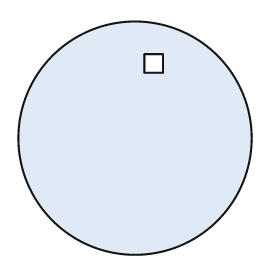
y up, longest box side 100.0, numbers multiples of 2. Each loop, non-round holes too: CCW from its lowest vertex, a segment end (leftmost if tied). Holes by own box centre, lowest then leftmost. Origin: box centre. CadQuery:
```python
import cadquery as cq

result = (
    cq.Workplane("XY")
    .moveTo(0.0, 0.0)
    .circle(50.0)
    .moveTo(4.0, 28.0)
    .lineTo(12.0, 28.0)
    .lineTo(12.0, 36.0)
    .lineTo(4.0, 36.0)
    .close()
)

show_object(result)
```